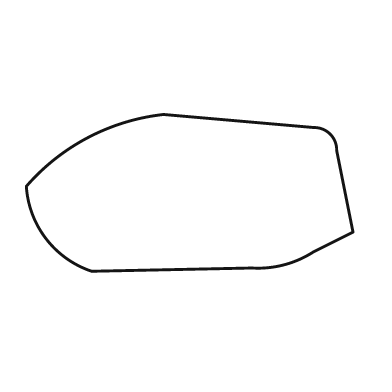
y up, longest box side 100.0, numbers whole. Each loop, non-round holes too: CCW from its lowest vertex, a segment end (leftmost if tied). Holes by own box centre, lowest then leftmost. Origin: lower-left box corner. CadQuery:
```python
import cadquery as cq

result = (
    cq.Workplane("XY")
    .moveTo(20.0, 0.0)
    .lineTo(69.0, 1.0)
    .threePointArc((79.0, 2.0), (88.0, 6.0))
    .lineTo(100.0, 12.0)
    .lineTo(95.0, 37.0)
    .threePointArc((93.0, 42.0), (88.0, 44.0))
    .lineTo(42.0, 48.0)
    .threePointArc((19.0, 41.0), (0.0, 26.0))
    .threePointArc((6.0, 10.0), (20.0, 0.0))
    .close()
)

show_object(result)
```